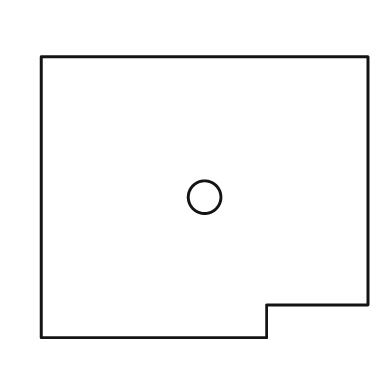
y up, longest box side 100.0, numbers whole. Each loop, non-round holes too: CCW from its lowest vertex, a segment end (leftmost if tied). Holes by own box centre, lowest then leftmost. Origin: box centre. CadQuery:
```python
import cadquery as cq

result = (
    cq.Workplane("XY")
    .moveTo(-50.0, -43.0)
    .lineTo(19.0, -43.0)
    .lineTo(19.0, -33.0)
    .lineTo(50.0, -33.0)
    .lineTo(50.0, 43.0)
    .lineTo(-50.0, 43.0)
    .close()
    .moveTo(0.0, 0.0)
    .circle(5.0)
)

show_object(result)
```